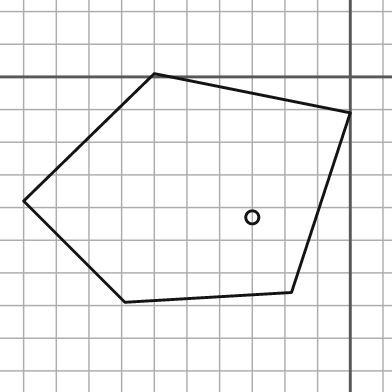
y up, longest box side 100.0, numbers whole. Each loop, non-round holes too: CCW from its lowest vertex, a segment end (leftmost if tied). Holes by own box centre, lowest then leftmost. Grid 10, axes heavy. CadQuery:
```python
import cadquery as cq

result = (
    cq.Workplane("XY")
    .moveTo(-69.0, -69.0)
    .lineTo(-18.0, -66.0)
    .lineTo(0.0, -11.0)
    .lineTo(-60.0, 1.0)
    .lineTo(-100.0, -38.0)
    .close()
    .moveTo(-30.0, -43.0)
    .circle(2.0)
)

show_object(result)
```